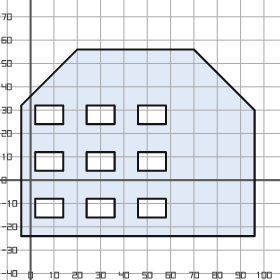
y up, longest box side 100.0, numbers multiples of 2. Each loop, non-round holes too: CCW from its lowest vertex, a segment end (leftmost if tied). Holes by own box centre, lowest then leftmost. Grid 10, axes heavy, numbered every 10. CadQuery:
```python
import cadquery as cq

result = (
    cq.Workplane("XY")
    .moveTo(-4.0, -24.0)
    .lineTo(96.0, -24.0)
    .lineTo(96.0, 30.0)
    .lineTo(70.0, 56.0)
    .lineTo(20.0, 56.0)
    .lineTo(-4.0, 32.0)
    .close()
    .moveTo(2.0, -16.0)
    .lineTo(14.0, -16.0)
    .lineTo(14.0, -8.0)
    .lineTo(2.0, -8.0)
    .close()
    .moveTo(24.0, -16.0)
    .lineTo(36.0, -16.0)
    .lineTo(36.0, -8.0)
    .lineTo(24.0, -8.0)
    .close()
    .moveTo(46.0, -16.0)
    .lineTo(58.0, -16.0)
    .lineTo(58.0, -8.0)
    .lineTo(46.0, -8.0)
    .close()
    .moveTo(2.0, 4.0)
    .lineTo(14.0, 4.0)
    .lineTo(14.0, 12.0)
    .lineTo(2.0, 12.0)
    .close()
    .moveTo(24.0, 4.0)
    .lineTo(36.0, 4.0)
    .lineTo(36.0, 12.0)
    .lineTo(24.0, 12.0)
    .close()
    .moveTo(46.0, 4.0)
    .lineTo(58.0, 4.0)
    .lineTo(58.0, 12.0)
    .lineTo(46.0, 12.0)
    .close()
    .moveTo(2.0, 24.0)
    .lineTo(14.0, 24.0)
    .lineTo(14.0, 32.0)
    .lineTo(2.0, 32.0)
    .close()
    .moveTo(24.0, 24.0)
    .lineTo(36.0, 24.0)
    .lineTo(36.0, 32.0)
    .lineTo(24.0, 32.0)
    .close()
    .moveTo(46.0, 24.0)
    .lineTo(58.0, 24.0)
    .lineTo(58.0, 32.0)
    .lineTo(46.0, 32.0)
    .close()
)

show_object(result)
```